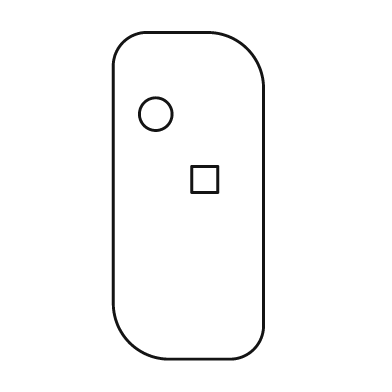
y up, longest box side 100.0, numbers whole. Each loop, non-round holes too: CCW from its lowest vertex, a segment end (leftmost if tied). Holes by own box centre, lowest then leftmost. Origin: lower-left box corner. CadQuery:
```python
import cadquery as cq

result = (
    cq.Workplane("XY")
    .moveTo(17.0, 0.0)
    .lineTo(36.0, 0.0)
    .threePointArc((43.0, 3.0), (46.0, 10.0))
    .lineTo(46.0, 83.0)
    .threePointArc((41.0, 95.0), (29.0, 100.0))
    .lineTo(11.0, 100.0)
    .threePointArc((3.0, 97.0), (0.0, 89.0))
    .lineTo(0.0, 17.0)
    .threePointArc((5.0, 5.0), (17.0, 0.0))
    .close()
    .moveTo(24.0, 51.0)
    .lineTo(32.0, 51.0)
    .lineTo(32.0, 59.0)
    .lineTo(24.0, 59.0)
    .close()
    .moveTo(13.0, 75.0)
    .circle(5.0)
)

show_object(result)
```